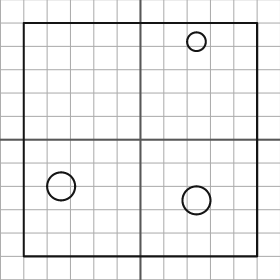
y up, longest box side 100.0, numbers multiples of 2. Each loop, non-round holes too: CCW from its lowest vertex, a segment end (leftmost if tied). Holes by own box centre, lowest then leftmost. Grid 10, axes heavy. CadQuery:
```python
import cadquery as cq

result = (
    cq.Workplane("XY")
    .moveTo(-50.0, -50.0)
    .lineTo(50.0, -50.0)
    .lineTo(50.0, 50.0)
    .lineTo(-50.0, 50.0)
    .close()
    .moveTo(24.0, -26.0)
    .circle(6.0)
    .moveTo(-34.0, -20.0)
    .circle(6.0)
    .moveTo(24.0, 42.0)
    .circle(4.0)
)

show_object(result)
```